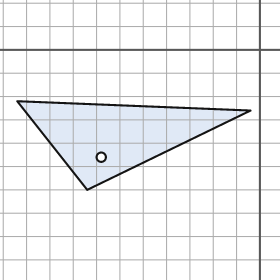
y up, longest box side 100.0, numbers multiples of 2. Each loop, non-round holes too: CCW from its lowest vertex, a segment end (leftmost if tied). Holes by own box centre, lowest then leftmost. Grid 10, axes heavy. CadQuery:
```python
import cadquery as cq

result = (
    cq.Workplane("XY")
    .moveTo(-74.0, -60.0)
    .lineTo(-4.0, -26.0)
    .lineTo(-104.0, -22.0)
    .close()
    .moveTo(-68.0, -46.0)
    .circle(2.0)
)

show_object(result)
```